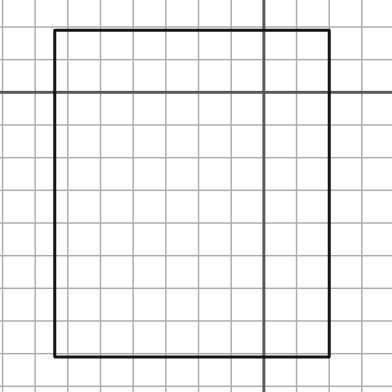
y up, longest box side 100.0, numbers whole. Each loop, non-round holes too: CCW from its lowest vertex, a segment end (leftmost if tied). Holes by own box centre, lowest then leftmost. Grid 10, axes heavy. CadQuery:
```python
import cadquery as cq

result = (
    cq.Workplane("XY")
    .moveTo(-64.0, -81.0)
    .lineTo(20.0, -81.0)
    .lineTo(20.0, 19.0)
    .lineTo(-64.0, 19.0)
    .close()
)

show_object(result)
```